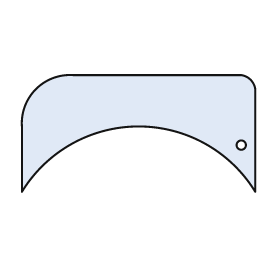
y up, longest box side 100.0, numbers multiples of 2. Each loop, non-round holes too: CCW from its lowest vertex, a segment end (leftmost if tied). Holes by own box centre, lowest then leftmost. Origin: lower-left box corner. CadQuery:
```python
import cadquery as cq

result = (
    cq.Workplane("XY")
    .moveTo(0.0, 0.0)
    .threePointArc((50.0, 28.0), (100.0, 0.0))
    .lineTo(100.0, 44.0)
    .threePointArc((98.0, 48.0), (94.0, 50.0))
    .lineTo(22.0, 50.0)
    .threePointArc((6.0, 44.0), (0.0, 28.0))
    .close()
    .moveTo(94.0, 20.0)
    .circle(2.0)
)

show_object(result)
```